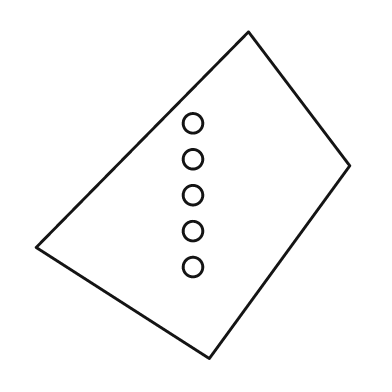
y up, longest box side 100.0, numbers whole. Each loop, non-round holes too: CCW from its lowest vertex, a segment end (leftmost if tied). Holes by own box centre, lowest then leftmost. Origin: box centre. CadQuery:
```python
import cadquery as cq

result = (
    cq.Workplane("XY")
    .moveTo(5.0, -50.0)
    .lineTo(48.0, 9.0)
    .lineTo(17.0, 50.0)
    .lineTo(-48.0, -16.0)
    .close()
    .moveTo(0.0, -22.0)
    .circle(3.0)
    .moveTo(0.0, -11.0)
    .circle(3.0)
    .moveTo(0.0, 0.0)
    .circle(3.0)
    .moveTo(0.0, 11.0)
    .circle(3.0)
    .moveTo(0.0, 22.0)
    .circle(3.0)
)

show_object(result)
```